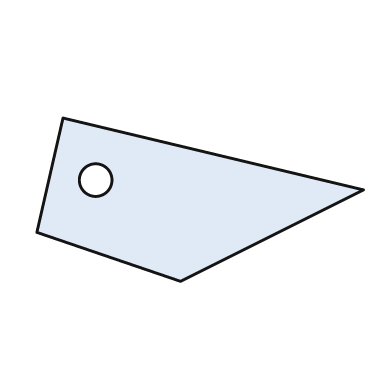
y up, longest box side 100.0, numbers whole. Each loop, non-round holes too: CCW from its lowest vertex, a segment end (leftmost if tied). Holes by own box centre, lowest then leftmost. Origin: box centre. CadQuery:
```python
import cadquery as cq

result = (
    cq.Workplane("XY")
    .moveTo(-6.0, -25.0)
    .lineTo(50.0, 3.0)
    .lineTo(-42.0, 25.0)
    .lineTo(-50.0, -10.0)
    .close()
    .moveTo(-32.0, 6.0)
    .circle(5.0)
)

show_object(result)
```